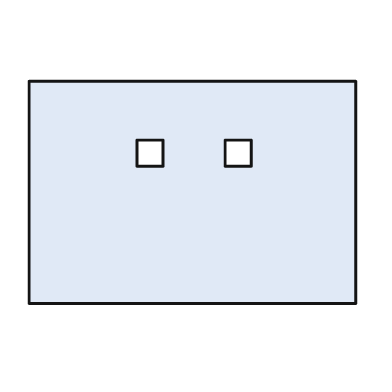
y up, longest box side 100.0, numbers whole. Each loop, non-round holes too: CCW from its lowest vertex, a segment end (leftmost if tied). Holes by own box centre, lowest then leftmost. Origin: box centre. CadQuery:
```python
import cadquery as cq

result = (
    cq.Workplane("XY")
    .moveTo(-50.0, -34.0)
    .lineTo(50.0, -34.0)
    .lineTo(50.0, 34.0)
    .lineTo(-50.0, 34.0)
    .close()
    .moveTo(-17.0, 8.0)
    .lineTo(-9.0, 8.0)
    .lineTo(-9.0, 16.0)
    .lineTo(-17.0, 16.0)
    .close()
    .moveTo(10.0, 8.0)
    .lineTo(18.0, 8.0)
    .lineTo(18.0, 16.0)
    .lineTo(10.0, 16.0)
    .close()
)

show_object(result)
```